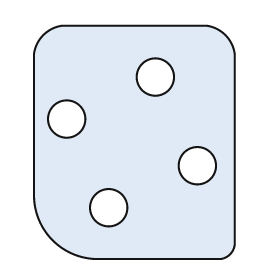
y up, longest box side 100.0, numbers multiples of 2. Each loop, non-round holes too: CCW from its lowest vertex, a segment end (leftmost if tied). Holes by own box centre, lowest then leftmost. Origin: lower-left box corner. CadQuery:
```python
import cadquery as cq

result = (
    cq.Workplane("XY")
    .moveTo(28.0, 0.0)
    .lineTo(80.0, 0.0)
    .threePointArc((84.0, 2.0), (86.0, 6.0))
    .lineTo(86.0, 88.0)
    .threePointArc((82.0, 96.0), (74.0, 100.0))
    .lineTo(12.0, 100.0)
    .threePointArc((4.0, 96.0), (0.0, 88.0))
    .lineTo(0.0, 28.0)
    .threePointArc((8.0, 8.0), (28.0, 0.0))
    .close()
    .moveTo(32.0, 22.0)
    .circle(8.0)
    .moveTo(70.0, 40.0)
    .circle(8.0)
    .moveTo(14.0, 60.0)
    .circle(8.0)
    .moveTo(52.0, 78.0)
    .circle(8.0)
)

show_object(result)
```